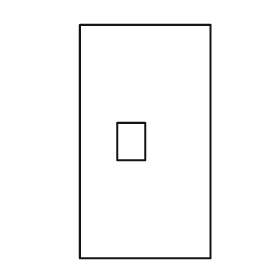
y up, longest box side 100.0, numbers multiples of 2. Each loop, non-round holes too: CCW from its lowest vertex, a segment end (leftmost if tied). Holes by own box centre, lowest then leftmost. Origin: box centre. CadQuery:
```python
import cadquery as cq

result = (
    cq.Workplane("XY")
    .moveTo(-28.0, -50.0)
    .lineTo(28.0, -50.0)
    .lineTo(28.0, 50.0)
    .lineTo(-28.0, 50.0)
    .close()
    .moveTo(-12.0, -8.0)
    .lineTo(0.0, -8.0)
    .lineTo(0.0, 8.0)
    .lineTo(-12.0, 8.0)
    .close()
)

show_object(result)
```